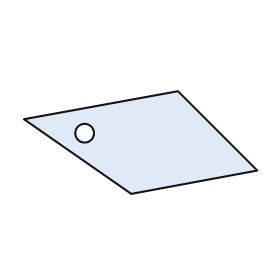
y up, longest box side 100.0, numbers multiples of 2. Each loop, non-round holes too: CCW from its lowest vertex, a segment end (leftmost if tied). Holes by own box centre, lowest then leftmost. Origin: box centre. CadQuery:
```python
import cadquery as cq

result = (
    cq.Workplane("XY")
    .moveTo(-4.0, -22.0)
    .lineTo(50.0, -12.0)
    .lineTo(16.0, 22.0)
    .lineTo(-50.0, 10.0)
    .close()
    .moveTo(-24.0, 4.0)
    .circle(4.0)
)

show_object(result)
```